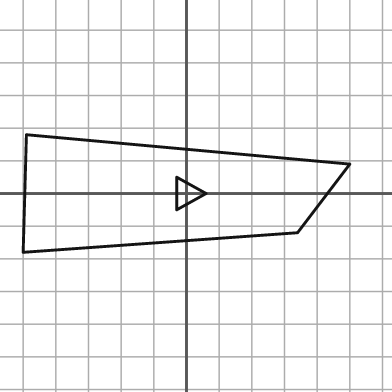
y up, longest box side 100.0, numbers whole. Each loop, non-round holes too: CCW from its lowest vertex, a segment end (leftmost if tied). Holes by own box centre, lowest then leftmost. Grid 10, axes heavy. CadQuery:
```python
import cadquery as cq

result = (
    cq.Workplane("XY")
    .moveTo(-50.0, -18.0)
    .lineTo(34.0, -12.0)
    .lineTo(50.0, 9.0)
    .lineTo(-49.0, 18.0)
    .close()
    .moveTo(-3.0, -5.0)
    .lineTo(6.0, 0.0)
    .lineTo(-3.0, 5.0)
    .close()
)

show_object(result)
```